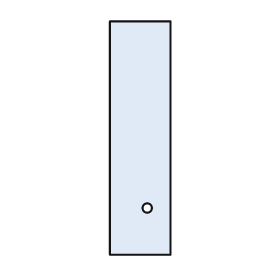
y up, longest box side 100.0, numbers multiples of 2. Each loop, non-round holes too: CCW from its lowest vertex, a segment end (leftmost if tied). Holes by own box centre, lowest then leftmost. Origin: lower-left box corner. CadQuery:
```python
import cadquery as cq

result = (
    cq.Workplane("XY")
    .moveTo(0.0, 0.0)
    .lineTo(26.0, 0.0)
    .lineTo(26.0, 100.0)
    .lineTo(0.0, 100.0)
    .close()
    .moveTo(16.0, 20.0)
    .circle(2.0)
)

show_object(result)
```